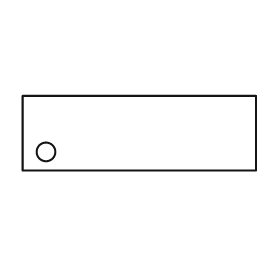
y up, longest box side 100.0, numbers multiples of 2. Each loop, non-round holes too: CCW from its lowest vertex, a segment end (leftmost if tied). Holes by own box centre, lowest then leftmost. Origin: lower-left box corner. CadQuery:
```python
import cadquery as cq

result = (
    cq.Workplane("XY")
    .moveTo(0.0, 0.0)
    .lineTo(100.0, 0.0)
    .lineTo(100.0, 32.0)
    .lineTo(0.0, 32.0)
    .close()
    .moveTo(10.0, 8.0)
    .circle(4.0)
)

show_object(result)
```